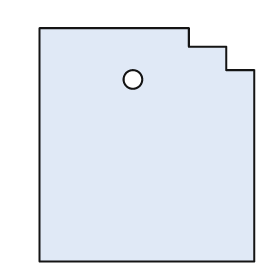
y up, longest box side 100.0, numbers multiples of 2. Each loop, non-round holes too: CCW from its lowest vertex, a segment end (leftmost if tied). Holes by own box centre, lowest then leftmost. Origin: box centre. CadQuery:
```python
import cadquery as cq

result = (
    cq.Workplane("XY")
    .moveTo(-46.0, -50.0)
    .lineTo(46.0, -50.0)
    .lineTo(46.0, 32.0)
    .lineTo(34.0, 32.0)
    .lineTo(34.0, 42.0)
    .lineTo(18.0, 42.0)
    .lineTo(18.0, 50.0)
    .lineTo(-46.0, 50.0)
    .close()
    .moveTo(-6.0, 28.0)
    .circle(4.0)
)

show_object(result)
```